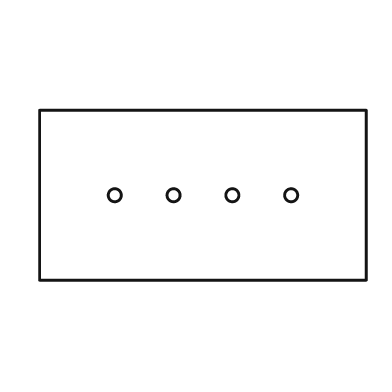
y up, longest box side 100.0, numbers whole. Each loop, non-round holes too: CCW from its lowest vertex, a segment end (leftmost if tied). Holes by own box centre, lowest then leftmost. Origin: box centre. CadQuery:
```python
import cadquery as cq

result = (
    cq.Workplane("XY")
    .moveTo(-50.0, -26.0)
    .lineTo(50.0, -26.0)
    .lineTo(50.0, 26.0)
    .lineTo(-50.0, 26.0)
    .close()
    .moveTo(-27.0, 0.0)
    .circle(2.0)
    .moveTo(-9.0, 0.0)
    .circle(2.0)
    .moveTo(9.0, 0.0)
    .circle(2.0)
    .moveTo(27.0, 0.0)
    .circle(2.0)
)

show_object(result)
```